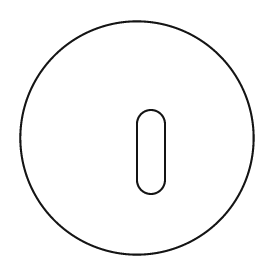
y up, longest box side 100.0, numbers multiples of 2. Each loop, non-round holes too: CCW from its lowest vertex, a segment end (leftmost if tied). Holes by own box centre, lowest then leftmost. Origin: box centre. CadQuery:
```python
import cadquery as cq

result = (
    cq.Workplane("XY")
    .moveTo(0.0, 0.0)
    .circle(50.0)
    .moveTo(0.0, -18.0)
    .threePointArc((6.0, -24.0), (12.0, -18.0))
    .lineTo(12.0, 6.0)
    .threePointArc((6.0, 12.0), (0.0, 6.0))
    .close()
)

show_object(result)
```